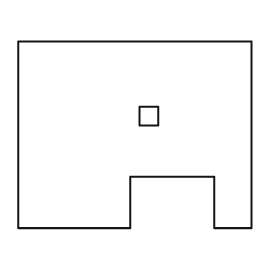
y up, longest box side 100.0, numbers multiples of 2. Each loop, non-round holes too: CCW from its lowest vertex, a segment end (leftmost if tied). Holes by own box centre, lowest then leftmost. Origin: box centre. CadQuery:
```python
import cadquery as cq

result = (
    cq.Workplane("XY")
    .moveTo(-50.0, -40.0)
    .lineTo(-2.0, -40.0)
    .lineTo(-2.0, -18.0)
    .lineTo(34.0, -18.0)
    .lineTo(34.0, -40.0)
    .lineTo(50.0, -40.0)
    .lineTo(50.0, 40.0)
    .lineTo(-50.0, 40.0)
    .close()
    .moveTo(2.0, 4.0)
    .lineTo(10.0, 4.0)
    .lineTo(10.0, 12.0)
    .lineTo(2.0, 12.0)
    .close()
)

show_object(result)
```